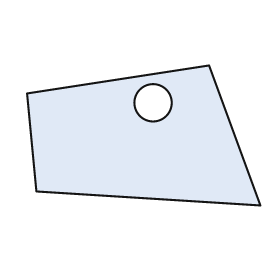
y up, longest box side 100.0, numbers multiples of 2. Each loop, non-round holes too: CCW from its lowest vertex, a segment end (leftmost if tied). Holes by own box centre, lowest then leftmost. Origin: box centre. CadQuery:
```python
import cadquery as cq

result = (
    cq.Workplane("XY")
    .moveTo(50.0, -30.0)
    .lineTo(28.0, 30.0)
    .lineTo(-50.0, 18.0)
    .lineTo(-46.0, -24.0)
    .close()
    .moveTo(4.0, 14.0)
    .circle(8.0)
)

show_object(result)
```